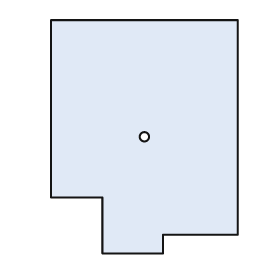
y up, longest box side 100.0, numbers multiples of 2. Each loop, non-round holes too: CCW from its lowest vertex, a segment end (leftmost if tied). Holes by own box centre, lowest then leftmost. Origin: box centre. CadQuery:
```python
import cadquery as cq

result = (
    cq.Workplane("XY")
    .moveTo(-18.0, -50.0)
    .lineTo(8.0, -50.0)
    .lineTo(8.0, -42.0)
    .lineTo(40.0, -42.0)
    .lineTo(40.0, 50.0)
    .lineTo(-40.0, 50.0)
    .lineTo(-40.0, -26.0)
    .lineTo(-18.0, -26.0)
    .close()
    .moveTo(0.0, 0.0)
    .circle(2.0)
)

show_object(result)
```